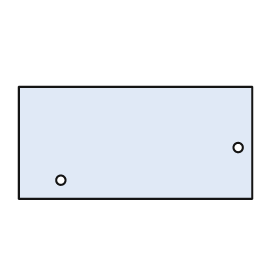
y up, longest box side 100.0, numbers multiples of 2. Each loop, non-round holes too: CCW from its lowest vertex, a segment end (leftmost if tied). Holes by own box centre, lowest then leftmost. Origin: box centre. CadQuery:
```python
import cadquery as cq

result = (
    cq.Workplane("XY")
    .moveTo(-50.0, -24.0)
    .lineTo(50.0, -24.0)
    .lineTo(50.0, 24.0)
    .lineTo(-50.0, 24.0)
    .close()
    .moveTo(-32.0, -16.0)
    .circle(2.0)
    .moveTo(44.0, -2.0)
    .circle(2.0)
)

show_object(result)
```